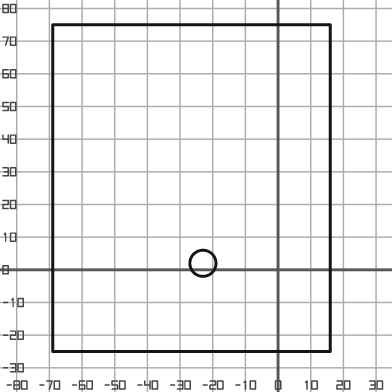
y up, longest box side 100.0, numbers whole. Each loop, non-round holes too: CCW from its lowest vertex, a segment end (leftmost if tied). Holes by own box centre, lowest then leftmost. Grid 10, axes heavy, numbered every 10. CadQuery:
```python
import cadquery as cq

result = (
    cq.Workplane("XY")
    .moveTo(-69.0, -25.0)
    .lineTo(16.0, -25.0)
    .lineTo(16.0, 75.0)
    .lineTo(-69.0, 75.0)
    .close()
    .moveTo(-23.0, 2.0)
    .circle(4.0)
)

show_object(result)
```